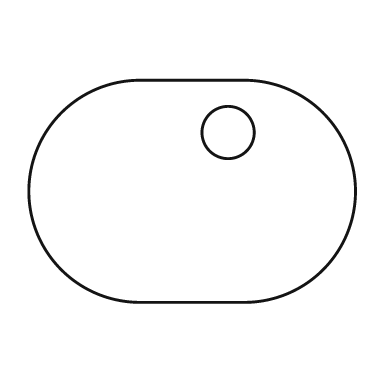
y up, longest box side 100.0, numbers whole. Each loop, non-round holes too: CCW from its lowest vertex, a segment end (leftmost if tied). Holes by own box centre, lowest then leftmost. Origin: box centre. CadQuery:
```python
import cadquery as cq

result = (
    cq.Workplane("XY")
    .moveTo(-16.0, -34.0)
    .lineTo(16.0, -34.0)
    .threePointArc((50.0, 0.0), (16.0, 34.0))
    .lineTo(-16.0, 34.0)
    .threePointArc((-50.0, 0.0), (-16.0, -34.0))
    .close()
    .moveTo(11.0, 18.0)
    .circle(8.0)
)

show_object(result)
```